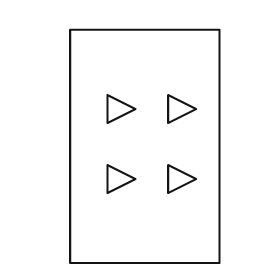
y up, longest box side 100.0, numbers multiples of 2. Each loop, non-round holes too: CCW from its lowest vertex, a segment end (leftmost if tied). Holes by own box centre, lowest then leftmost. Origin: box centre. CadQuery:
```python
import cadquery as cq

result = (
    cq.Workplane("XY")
    .moveTo(-32.0, -50.0)
    .lineTo(32.0, -50.0)
    .lineTo(32.0, 50.0)
    .lineTo(-32.0, 50.0)
    .close()
    .moveTo(-16.0, -20.0)
    .lineTo(-4.0, -14.0)
    .lineTo(-16.0, -8.0)
    .close()
    .moveTo(10.0, -20.0)
    .lineTo(22.0, -14.0)
    .lineTo(10.0, -8.0)
    .close()
    .moveTo(-16.0, 10.0)
    .lineTo(-4.0, 16.0)
    .lineTo(-16.0, 22.0)
    .close()
    .moveTo(10.0, 10.0)
    .lineTo(22.0, 16.0)
    .lineTo(10.0, 22.0)
    .close()
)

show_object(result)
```